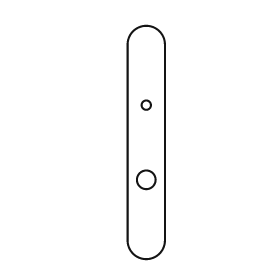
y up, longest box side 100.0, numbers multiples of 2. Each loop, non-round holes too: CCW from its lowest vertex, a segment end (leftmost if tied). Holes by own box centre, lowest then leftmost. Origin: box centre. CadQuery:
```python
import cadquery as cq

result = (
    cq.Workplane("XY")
    .moveTo(-8.0, -42.0)
    .threePointArc((0.0, -50.0), (8.0, -42.0))
    .lineTo(8.0, 42.0)
    .threePointArc((0.0, 50.0), (-8.0, 42.0))
    .close()
    .moveTo(0.0, -16.0)
    .circle(4.0)
    .moveTo(0.0, 16.0)
    .circle(2.0)
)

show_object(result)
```